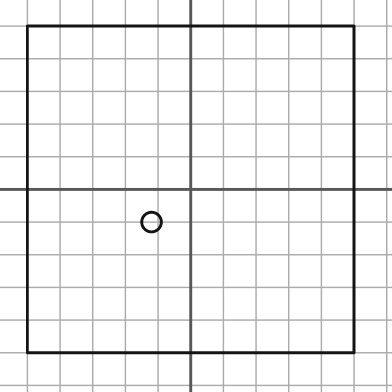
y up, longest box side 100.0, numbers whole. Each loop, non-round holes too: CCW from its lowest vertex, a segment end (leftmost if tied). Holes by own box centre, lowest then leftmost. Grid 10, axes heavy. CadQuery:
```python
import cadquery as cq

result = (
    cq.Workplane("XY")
    .moveTo(-50.0, -50.0)
    .lineTo(50.0, -50.0)
    .lineTo(50.0, 50.0)
    .lineTo(-50.0, 50.0)
    .close()
    .moveTo(-12.0, -10.0)
    .circle(3.0)
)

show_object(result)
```